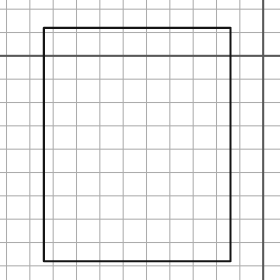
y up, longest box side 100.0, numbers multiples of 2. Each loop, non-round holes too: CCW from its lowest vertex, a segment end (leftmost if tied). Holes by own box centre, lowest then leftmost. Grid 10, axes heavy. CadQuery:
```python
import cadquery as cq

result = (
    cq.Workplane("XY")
    .moveTo(-94.0, -88.0)
    .lineTo(-14.0, -88.0)
    .lineTo(-14.0, 12.0)
    .lineTo(-94.0, 12.0)
    .close()
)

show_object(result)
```